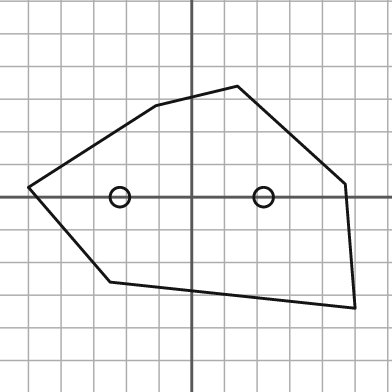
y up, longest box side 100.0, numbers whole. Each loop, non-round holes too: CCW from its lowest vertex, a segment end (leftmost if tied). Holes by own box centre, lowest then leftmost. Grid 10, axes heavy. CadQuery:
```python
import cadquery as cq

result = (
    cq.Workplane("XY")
    .moveTo(50.0, -34.0)
    .lineTo(47.0, 4.0)
    .lineTo(14.0, 34.0)
    .lineTo(-11.0, 28.0)
    .lineTo(-50.0, 3.0)
    .lineTo(-25.0, -26.0)
    .close()
    .moveTo(-22.0, 0.0)
    .circle(3.0)
    .moveTo(22.0, 0.0)
    .circle(3.0)
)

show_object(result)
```